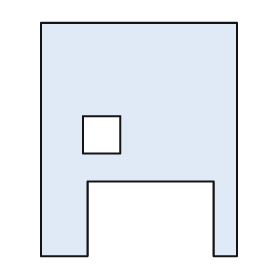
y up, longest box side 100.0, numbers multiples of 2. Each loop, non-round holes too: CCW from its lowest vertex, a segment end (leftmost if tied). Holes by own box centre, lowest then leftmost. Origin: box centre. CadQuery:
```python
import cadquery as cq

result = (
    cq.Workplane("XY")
    .moveTo(-42.0, -50.0)
    .lineTo(-22.0, -50.0)
    .lineTo(-22.0, -18.0)
    .lineTo(32.0, -18.0)
    .lineTo(32.0, -50.0)
    .lineTo(42.0, -50.0)
    .lineTo(42.0, 50.0)
    .lineTo(-42.0, 50.0)
    .close()
    .moveTo(-24.0, -6.0)
    .lineTo(-8.0, -6.0)
    .lineTo(-8.0, 10.0)
    .lineTo(-24.0, 10.0)
    .close()
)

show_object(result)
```